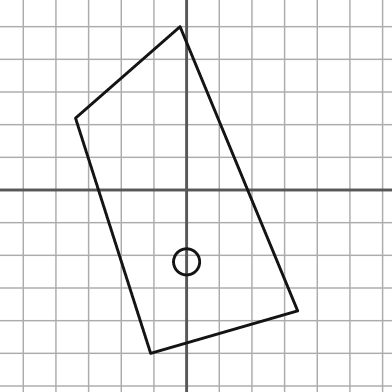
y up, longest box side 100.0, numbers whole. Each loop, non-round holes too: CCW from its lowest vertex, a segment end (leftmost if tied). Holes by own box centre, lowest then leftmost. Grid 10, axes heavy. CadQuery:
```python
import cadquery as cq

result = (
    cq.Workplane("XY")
    .moveTo(-11.0, -50.0)
    .lineTo(34.0, -37.0)
    .lineTo(-2.0, 50.0)
    .lineTo(-34.0, 22.0)
    .close()
    .moveTo(0.0, -22.0)
    .circle(4.0)
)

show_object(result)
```